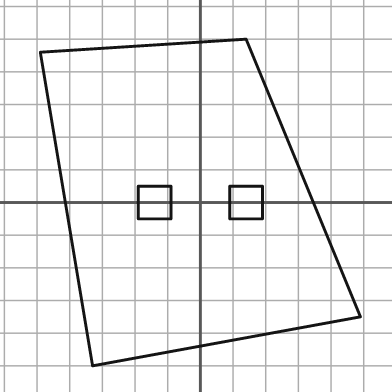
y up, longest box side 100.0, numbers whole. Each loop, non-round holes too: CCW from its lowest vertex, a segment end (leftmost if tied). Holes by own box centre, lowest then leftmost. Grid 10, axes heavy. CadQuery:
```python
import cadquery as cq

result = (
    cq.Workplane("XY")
    .moveTo(-33.0, -50.0)
    .lineTo(49.0, -35.0)
    .lineTo(14.0, 50.0)
    .lineTo(-49.0, 46.0)
    .close()
    .moveTo(-19.0, -5.0)
    .lineTo(-9.0, -5.0)
    .lineTo(-9.0, 5.0)
    .lineTo(-19.0, 5.0)
    .close()
    .moveTo(9.0, -5.0)
    .lineTo(19.0, -5.0)
    .lineTo(19.0, 5.0)
    .lineTo(9.0, 5.0)
    .close()
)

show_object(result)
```